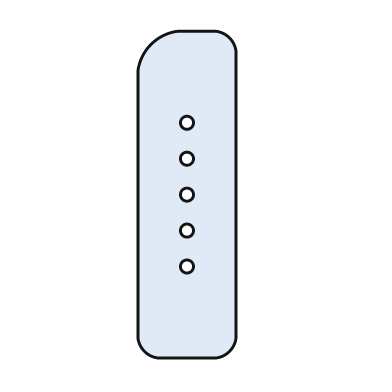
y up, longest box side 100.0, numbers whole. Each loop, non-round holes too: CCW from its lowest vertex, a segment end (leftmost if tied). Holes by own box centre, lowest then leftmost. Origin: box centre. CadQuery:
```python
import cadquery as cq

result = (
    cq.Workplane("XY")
    .moveTo(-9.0, -50.0)
    .lineTo(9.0, -50.0)
    .threePointArc((13.0, -48.0), (15.0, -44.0))
    .lineTo(15.0, 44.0)
    .threePointArc((13.0, 48.0), (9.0, 50.0))
    .lineTo(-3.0, 50.0)
    .threePointArc((-11.0, 46.0), (-15.0, 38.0))
    .lineTo(-15.0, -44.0)
    .threePointArc((-13.0, -48.0), (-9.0, -50.0))
    .close()
    .moveTo(0.0, -22.0)
    .circle(2.0)
    .moveTo(0.0, -11.0)
    .circle(2.0)
    .moveTo(0.0, 0.0)
    .circle(2.0)
    .moveTo(0.0, 11.0)
    .circle(2.0)
    .moveTo(0.0, 22.0)
    .circle(2.0)
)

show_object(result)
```